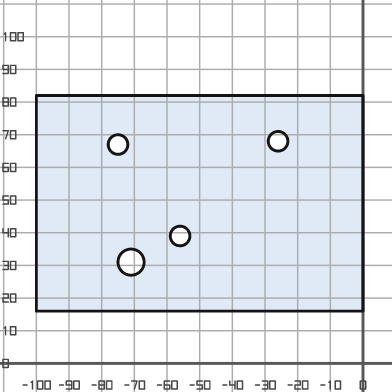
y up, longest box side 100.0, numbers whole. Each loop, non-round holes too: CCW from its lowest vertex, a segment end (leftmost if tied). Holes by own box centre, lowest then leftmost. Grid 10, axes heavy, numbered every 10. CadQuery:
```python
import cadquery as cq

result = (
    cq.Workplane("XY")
    .moveTo(-100.0, 16.0)
    .lineTo(0.0, 16.0)
    .lineTo(0.0, 82.0)
    .lineTo(-100.0, 82.0)
    .close()
    .moveTo(-71.0, 31.0)
    .circle(4.0)
    .moveTo(-56.0, 39.0)
    .circle(3.0)
    .moveTo(-75.0, 67.0)
    .circle(3.0)
    .moveTo(-26.0, 68.0)
    .circle(3.0)
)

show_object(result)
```